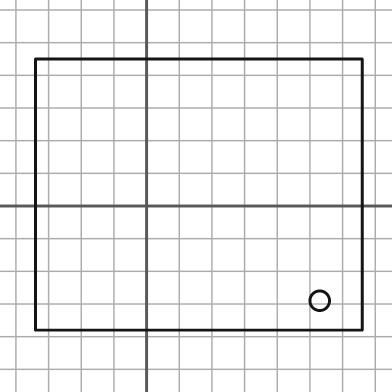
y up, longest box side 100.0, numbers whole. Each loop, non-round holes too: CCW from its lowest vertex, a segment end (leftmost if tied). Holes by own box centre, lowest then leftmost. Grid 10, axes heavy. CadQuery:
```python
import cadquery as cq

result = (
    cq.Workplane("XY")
    .moveTo(-34.0, -38.0)
    .lineTo(66.0, -38.0)
    .lineTo(66.0, 45.0)
    .lineTo(-34.0, 45.0)
    .close()
    .moveTo(53.0, -29.0)
    .circle(3.0)
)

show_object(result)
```